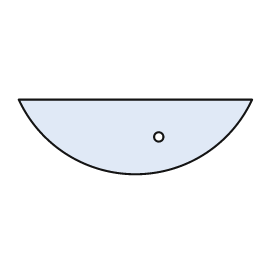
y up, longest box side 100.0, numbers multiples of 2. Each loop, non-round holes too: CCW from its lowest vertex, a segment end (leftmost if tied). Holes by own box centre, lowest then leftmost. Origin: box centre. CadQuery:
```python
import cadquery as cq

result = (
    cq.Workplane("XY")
    .moveTo(-50.0, 16.0)
    .threePointArc((0.0, -16.0), (50.0, 16.0))
    .close()
    .moveTo(10.0, 0.0)
    .circle(2.0)
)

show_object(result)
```